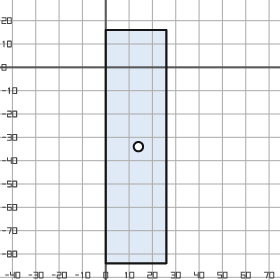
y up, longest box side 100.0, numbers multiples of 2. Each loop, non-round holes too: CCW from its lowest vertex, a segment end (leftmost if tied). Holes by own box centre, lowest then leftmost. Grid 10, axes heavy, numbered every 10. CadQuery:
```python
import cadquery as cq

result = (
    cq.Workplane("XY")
    .moveTo(0.0, -84.0)
    .lineTo(26.0, -84.0)
    .lineTo(26.0, 16.0)
    .lineTo(0.0, 16.0)
    .close()
    .moveTo(14.0, -34.0)
    .circle(2.0)
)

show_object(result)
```